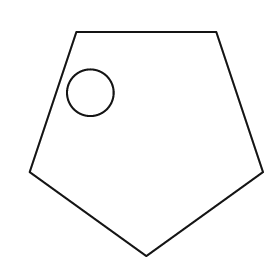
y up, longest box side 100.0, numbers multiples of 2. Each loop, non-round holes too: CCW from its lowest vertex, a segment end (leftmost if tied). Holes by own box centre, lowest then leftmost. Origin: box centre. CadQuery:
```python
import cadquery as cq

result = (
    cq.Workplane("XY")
    .moveTo(0.0, -48.0)
    .lineTo(50.0, -12.0)
    .lineTo(30.0, 48.0)
    .lineTo(-30.0, 48.0)
    .lineTo(-50.0, -12.0)
    .close()
    .moveTo(-24.0, 22.0)
    .circle(10.0)
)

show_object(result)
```